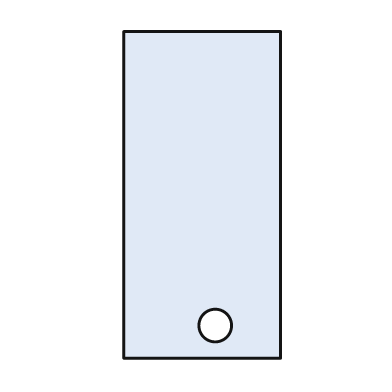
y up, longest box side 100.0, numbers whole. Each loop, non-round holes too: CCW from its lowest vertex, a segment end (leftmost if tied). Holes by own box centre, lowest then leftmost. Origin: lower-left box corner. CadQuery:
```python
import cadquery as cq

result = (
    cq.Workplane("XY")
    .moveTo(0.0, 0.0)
    .lineTo(48.0, 0.0)
    .lineTo(48.0, 100.0)
    .lineTo(0.0, 100.0)
    .close()
    .moveTo(28.0, 10.0)
    .circle(5.0)
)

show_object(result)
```